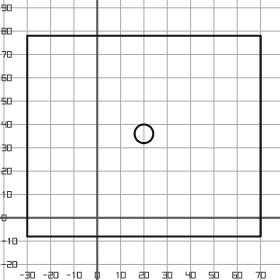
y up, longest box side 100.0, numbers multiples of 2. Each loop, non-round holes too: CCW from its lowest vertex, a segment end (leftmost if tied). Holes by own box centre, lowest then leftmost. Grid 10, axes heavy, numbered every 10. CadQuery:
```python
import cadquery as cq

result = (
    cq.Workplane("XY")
    .moveTo(-30.0, -8.0)
    .lineTo(70.0, -8.0)
    .lineTo(70.0, 78.0)
    .lineTo(-30.0, 78.0)
    .close()
    .moveTo(20.0, 36.0)
    .circle(4.0)
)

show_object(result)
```